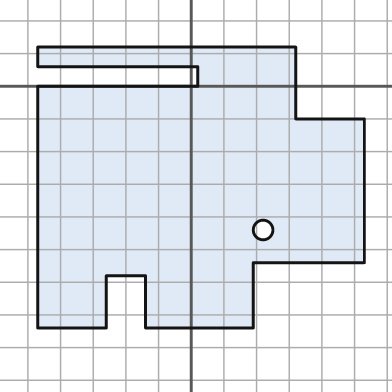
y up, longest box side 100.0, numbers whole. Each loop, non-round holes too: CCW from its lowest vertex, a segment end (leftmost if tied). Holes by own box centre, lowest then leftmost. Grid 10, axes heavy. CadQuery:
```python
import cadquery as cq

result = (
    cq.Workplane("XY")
    .moveTo(-47.0, -74.0)
    .lineTo(-26.0, -74.0)
    .lineTo(-26.0, -58.0)
    .lineTo(-14.0, -58.0)
    .lineTo(-14.0, -74.0)
    .lineTo(19.0, -74.0)
    .lineTo(19.0, -54.0)
    .lineTo(53.0, -54.0)
    .lineTo(53.0, -10.0)
    .lineTo(32.0, -10.0)
    .lineTo(32.0, 12.0)
    .lineTo(-47.0, 12.0)
    .lineTo(-47.0, 6.0)
    .lineTo(2.0, 6.0)
    .lineTo(2.0, 0.0)
    .lineTo(-47.0, 0.0)
    .close()
    .moveTo(22.0, -44.0)
    .circle(3.0)
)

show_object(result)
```